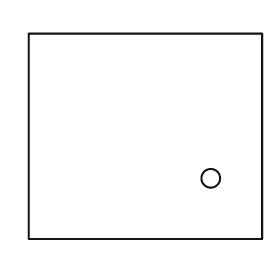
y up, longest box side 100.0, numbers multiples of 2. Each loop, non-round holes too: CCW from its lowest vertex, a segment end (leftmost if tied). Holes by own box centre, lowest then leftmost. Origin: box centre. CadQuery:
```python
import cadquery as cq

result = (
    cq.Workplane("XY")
    .moveTo(-50.0, -44.0)
    .lineTo(50.0, -44.0)
    .lineTo(50.0, 44.0)
    .lineTo(-50.0, 44.0)
    .close()
    .moveTo(28.0, -18.0)
    .circle(4.0)
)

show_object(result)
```